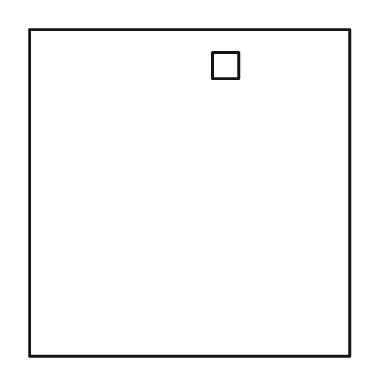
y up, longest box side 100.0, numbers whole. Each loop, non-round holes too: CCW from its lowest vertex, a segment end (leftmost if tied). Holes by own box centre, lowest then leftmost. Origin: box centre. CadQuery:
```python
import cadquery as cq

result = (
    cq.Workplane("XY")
    .moveTo(-49.0, -50.0)
    .lineTo(49.0, -50.0)
    .lineTo(49.0, 50.0)
    .lineTo(-49.0, 50.0)
    .close()
    .moveTo(7.0, 35.0)
    .lineTo(15.0, 35.0)
    .lineTo(15.0, 43.0)
    .lineTo(7.0, 43.0)
    .close()
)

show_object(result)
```